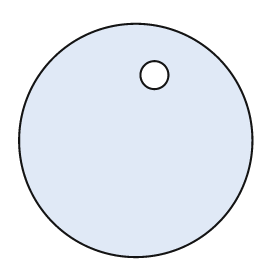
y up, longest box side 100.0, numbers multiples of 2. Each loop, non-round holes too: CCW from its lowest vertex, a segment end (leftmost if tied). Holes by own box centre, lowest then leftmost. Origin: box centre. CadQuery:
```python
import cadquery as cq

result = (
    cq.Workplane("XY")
    .moveTo(0.0, 0.0)
    .circle(50.0)
    .moveTo(8.0, 28.0)
    .circle(6.0)
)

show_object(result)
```